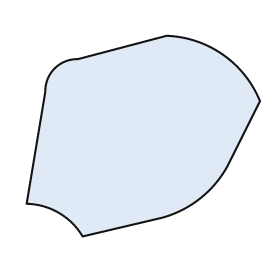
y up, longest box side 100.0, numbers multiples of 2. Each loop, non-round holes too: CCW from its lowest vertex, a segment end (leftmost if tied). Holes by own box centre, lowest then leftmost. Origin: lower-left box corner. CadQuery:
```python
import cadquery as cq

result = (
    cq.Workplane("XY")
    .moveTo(24.0, 0.0)
    .lineTo(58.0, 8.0)
    .threePointArc((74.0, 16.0), (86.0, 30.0))
    .lineTo(100.0, 58.0)
    .threePointArc((84.0, 78.0), (60.0, 86.0))
    .lineTo(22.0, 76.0)
    .threePointArc((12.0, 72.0), (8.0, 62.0))
    .lineTo(0.0, 14.0)
    .threePointArc((14.0, 10.0), (24.0, 0.0))
    .close()
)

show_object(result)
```